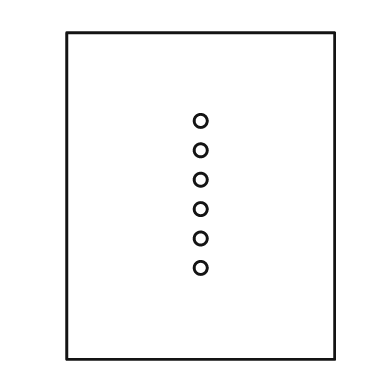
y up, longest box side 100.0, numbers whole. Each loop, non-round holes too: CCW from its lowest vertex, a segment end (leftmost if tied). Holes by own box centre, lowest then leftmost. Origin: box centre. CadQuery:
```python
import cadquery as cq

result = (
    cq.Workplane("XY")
    .moveTo(-41.0, -50.0)
    .lineTo(41.0, -50.0)
    .lineTo(41.0, 50.0)
    .lineTo(-41.0, 50.0)
    .close()
    .moveTo(0.0, -22.0)
    .circle(2.0)
    .moveTo(0.0, -13.0)
    .circle(2.0)
    .moveTo(0.0, -4.0)
    .circle(2.0)
    .moveTo(0.0, 5.0)
    .circle(2.0)
    .moveTo(0.0, 14.0)
    .circle(2.0)
    .moveTo(0.0, 23.0)
    .circle(2.0)
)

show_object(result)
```